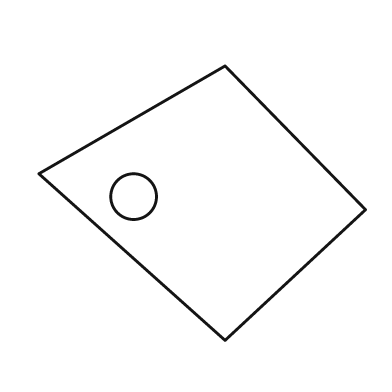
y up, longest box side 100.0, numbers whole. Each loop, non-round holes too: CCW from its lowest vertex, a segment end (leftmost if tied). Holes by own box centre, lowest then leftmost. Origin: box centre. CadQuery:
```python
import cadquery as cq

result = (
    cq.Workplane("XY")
    .moveTo(7.0, -42.0)
    .lineTo(50.0, -2.0)
    .lineTo(7.0, 42.0)
    .lineTo(-50.0, 9.0)
    .close()
    .moveTo(-21.0, 2.0)
    .circle(7.0)
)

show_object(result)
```